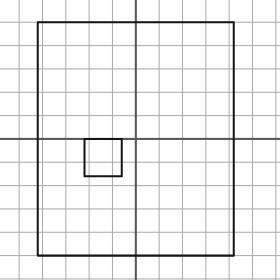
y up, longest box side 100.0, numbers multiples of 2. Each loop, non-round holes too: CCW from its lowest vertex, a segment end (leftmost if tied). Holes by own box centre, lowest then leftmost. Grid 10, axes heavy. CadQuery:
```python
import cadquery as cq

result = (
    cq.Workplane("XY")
    .moveTo(-42.0, -50.0)
    .lineTo(42.0, -50.0)
    .lineTo(42.0, 50.0)
    .lineTo(-42.0, 50.0)
    .close()
    .moveTo(-22.0, -16.0)
    .lineTo(-6.0, -16.0)
    .lineTo(-6.0, 0.0)
    .lineTo(-22.0, 0.0)
    .close()
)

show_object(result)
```